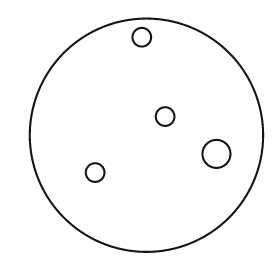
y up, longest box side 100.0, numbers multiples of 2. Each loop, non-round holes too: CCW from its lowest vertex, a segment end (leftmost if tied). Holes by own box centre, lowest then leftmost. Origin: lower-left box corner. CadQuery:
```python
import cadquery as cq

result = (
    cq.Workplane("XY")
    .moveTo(50.0, 50.0)
    .circle(50.0)
    .moveTo(28.0, 34.0)
    .circle(4.0)
    .moveTo(80.0, 42.0)
    .circle(6.0)
    .moveTo(58.0, 58.0)
    .circle(4.0)
    .moveTo(48.0, 92.0)
    .circle(4.0)
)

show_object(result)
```